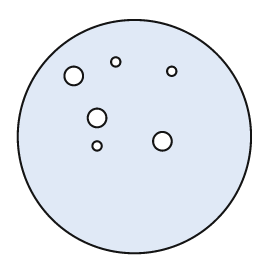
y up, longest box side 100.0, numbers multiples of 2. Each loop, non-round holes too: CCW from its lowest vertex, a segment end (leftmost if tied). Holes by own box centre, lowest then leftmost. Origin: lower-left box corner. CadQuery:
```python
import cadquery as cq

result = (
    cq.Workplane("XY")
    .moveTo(50.0, 50.0)
    .circle(50.0)
    .moveTo(34.0, 46.0)
    .circle(2.0)
    .moveTo(62.0, 48.0)
    .circle(4.0)
    .moveTo(34.0, 58.0)
    .circle(4.0)
    .moveTo(24.0, 76.0)
    .circle(4.0)
    .moveTo(66.0, 78.0)
    .circle(2.0)
    .moveTo(42.0, 82.0)
    .circle(2.0)
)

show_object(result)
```